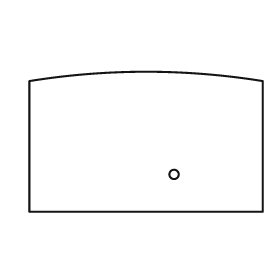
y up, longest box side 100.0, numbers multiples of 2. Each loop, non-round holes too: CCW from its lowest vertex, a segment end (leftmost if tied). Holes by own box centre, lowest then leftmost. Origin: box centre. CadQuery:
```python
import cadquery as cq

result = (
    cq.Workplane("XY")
    .moveTo(-50.0, -30.0)
    .lineTo(50.0, -30.0)
    .lineTo(50.0, 26.0)
    .threePointArc((0.0, 30.0), (-50.0, 26.0))
    .close()
    .moveTo(12.0, -14.0)
    .circle(2.0)
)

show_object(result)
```